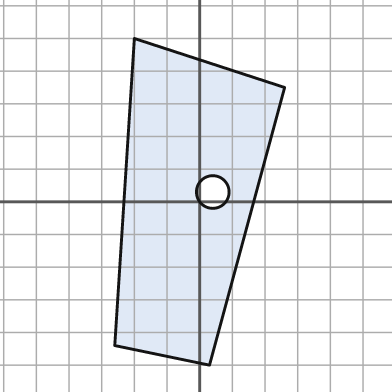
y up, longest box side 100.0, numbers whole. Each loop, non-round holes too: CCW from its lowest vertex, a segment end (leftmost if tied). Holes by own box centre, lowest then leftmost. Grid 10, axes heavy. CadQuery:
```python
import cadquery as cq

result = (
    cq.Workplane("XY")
    .moveTo(3.0, -50.0)
    .lineTo(26.0, 35.0)
    .lineTo(-20.0, 50.0)
    .lineTo(-26.0, -44.0)
    .close()
    .moveTo(4.0, 3.0)
    .circle(5.0)
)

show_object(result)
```